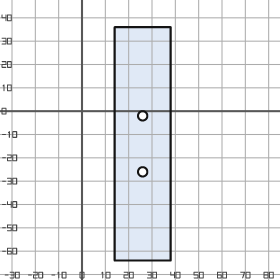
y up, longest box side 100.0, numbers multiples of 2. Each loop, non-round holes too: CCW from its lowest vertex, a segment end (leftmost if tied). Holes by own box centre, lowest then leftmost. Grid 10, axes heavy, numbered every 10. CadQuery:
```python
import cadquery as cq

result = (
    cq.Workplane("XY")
    .moveTo(14.0, -64.0)
    .lineTo(38.0, -64.0)
    .lineTo(38.0, 36.0)
    .lineTo(14.0, 36.0)
    .close()
    .moveTo(26.0, -26.0)
    .circle(2.0)
    .moveTo(26.0, -2.0)
    .circle(2.0)
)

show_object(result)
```